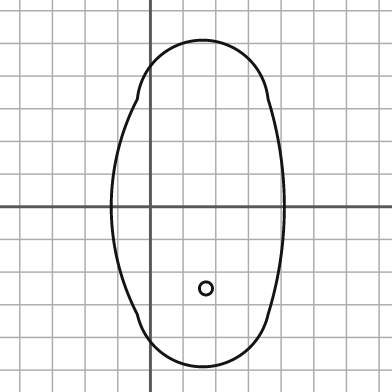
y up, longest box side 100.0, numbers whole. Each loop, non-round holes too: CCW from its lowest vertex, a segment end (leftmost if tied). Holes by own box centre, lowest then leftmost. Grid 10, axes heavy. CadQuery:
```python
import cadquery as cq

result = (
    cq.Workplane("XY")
    .moveTo(-4.0, -33.0)
    .threePointArc((16.0, -49.0), (36.0, -33.0))
    .threePointArc((41.0, 0.0), (36.0, 33.0))
    .threePointArc((16.0, 51.0), (-4.0, 33.0))
    .threePointArc((-12.0, 0.0), (-4.0, -33.0))
    .close()
    .moveTo(17.0, -25.0)
    .circle(2.0)
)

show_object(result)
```